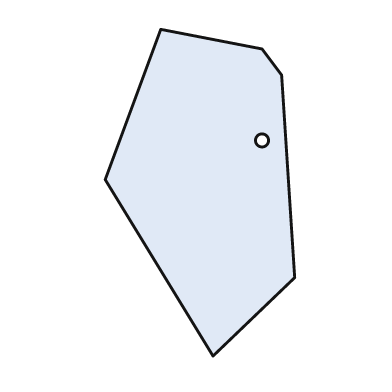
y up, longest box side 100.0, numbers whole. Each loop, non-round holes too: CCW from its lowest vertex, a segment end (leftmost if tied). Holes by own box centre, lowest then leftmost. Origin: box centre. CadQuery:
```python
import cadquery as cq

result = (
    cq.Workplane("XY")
    .moveTo(4.0, -50.0)
    .lineTo(29.0, -26.0)
    .lineTo(25.0, 36.0)
    .lineTo(19.0, 44.0)
    .lineTo(-12.0, 50.0)
    .lineTo(-29.0, 4.0)
    .close()
    .moveTo(19.0, 16.0)
    .circle(2.0)
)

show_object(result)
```